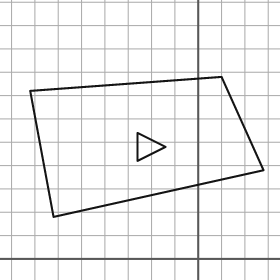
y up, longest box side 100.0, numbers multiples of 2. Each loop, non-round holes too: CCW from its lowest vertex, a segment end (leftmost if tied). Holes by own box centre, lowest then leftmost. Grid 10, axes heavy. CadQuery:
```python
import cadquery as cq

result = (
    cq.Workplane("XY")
    .moveTo(-62.0, 18.0)
    .lineTo(28.0, 38.0)
    .lineTo(10.0, 78.0)
    .lineTo(-72.0, 72.0)
    .close()
    .moveTo(-26.0, 42.0)
    .lineTo(-14.0, 48.0)
    .lineTo(-26.0, 54.0)
    .close()
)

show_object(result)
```